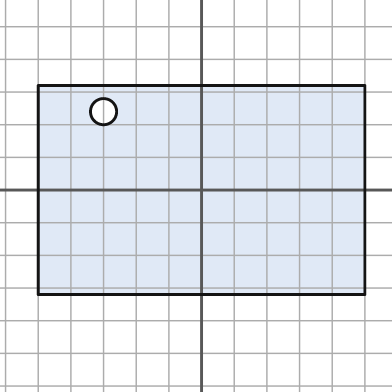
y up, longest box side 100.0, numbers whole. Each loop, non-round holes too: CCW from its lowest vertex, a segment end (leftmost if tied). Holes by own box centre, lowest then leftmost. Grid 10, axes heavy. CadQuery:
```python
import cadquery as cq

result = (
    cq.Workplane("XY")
    .moveTo(-50.0, -32.0)
    .lineTo(50.0, -32.0)
    .lineTo(50.0, 32.0)
    .lineTo(-50.0, 32.0)
    .close()
    .moveTo(-30.0, 24.0)
    .circle(4.0)
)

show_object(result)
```